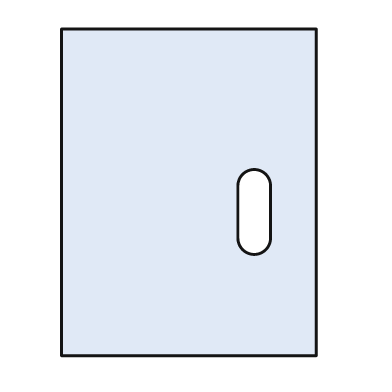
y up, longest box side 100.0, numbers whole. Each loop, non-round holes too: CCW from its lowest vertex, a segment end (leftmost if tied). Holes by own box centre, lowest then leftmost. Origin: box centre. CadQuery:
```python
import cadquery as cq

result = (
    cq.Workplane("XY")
    .moveTo(-39.0, -50.0)
    .lineTo(39.0, -50.0)
    .lineTo(39.0, 50.0)
    .lineTo(-39.0, 50.0)
    .close()
    .moveTo(15.0, -14.0)
    .threePointArc((20.0, -19.0), (25.0, -14.0))
    .lineTo(25.0, 2.0)
    .threePointArc((20.0, 7.0), (15.0, 2.0))
    .close()
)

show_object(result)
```